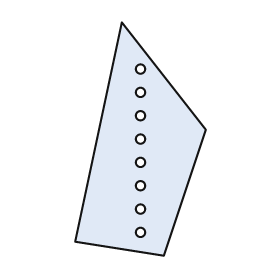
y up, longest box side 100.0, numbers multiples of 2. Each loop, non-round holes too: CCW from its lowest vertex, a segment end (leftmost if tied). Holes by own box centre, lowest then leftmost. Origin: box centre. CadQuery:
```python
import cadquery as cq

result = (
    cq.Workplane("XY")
    .moveTo(10.0, -50.0)
    .lineTo(28.0, 4.0)
    .lineTo(-8.0, 50.0)
    .lineTo(-28.0, -44.0)
    .close()
    .moveTo(0.0, -40.0)
    .circle(2.0)
    .moveTo(0.0, -30.0)
    .circle(2.0)
    .moveTo(0.0, -20.0)
    .circle(2.0)
    .moveTo(0.0, -10.0)
    .circle(2.0)
    .moveTo(0.0, 0.0)
    .circle(2.0)
    .moveTo(0.0, 10.0)
    .circle(2.0)
    .moveTo(0.0, 20.0)
    .circle(2.0)
    .moveTo(0.0, 30.0)
    .circle(2.0)
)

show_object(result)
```